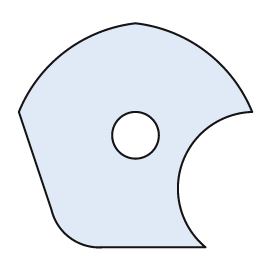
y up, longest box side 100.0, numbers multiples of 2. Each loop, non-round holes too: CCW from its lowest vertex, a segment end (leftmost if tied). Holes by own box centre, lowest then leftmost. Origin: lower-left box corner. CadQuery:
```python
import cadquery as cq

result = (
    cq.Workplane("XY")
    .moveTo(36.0, 0.0)
    .lineTo(80.0, 0.0)
    .threePointArc((70.0, 36.0), (100.0, 58.0))
    .threePointArc((80.0, 84.0), (50.0, 96.0))
    .threePointArc((20.0, 84.0), (0.0, 58.0))
    .lineTo(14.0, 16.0)
    .threePointArc((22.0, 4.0), (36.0, 0.0))
    .close()
    .moveTo(50.0, 48.0)
    .circle(10.0)
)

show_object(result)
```